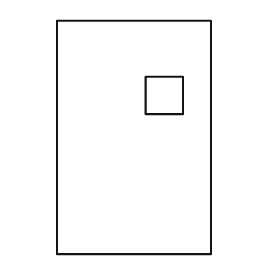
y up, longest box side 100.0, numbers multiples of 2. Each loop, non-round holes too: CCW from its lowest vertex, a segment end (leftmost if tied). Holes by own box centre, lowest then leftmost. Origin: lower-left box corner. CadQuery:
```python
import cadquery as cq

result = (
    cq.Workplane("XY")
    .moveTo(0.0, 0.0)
    .lineTo(66.0, 0.0)
    .lineTo(66.0, 100.0)
    .lineTo(0.0, 100.0)
    .close()
    .moveTo(38.0, 60.0)
    .lineTo(54.0, 60.0)
    .lineTo(54.0, 76.0)
    .lineTo(38.0, 76.0)
    .close()
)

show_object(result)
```